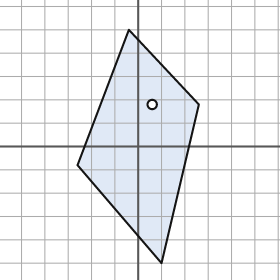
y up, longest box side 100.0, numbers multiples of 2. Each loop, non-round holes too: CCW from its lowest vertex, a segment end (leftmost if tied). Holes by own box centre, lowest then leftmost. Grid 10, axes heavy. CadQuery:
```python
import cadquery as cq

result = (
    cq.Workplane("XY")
    .moveTo(10.0, -50.0)
    .lineTo(26.0, 18.0)
    .lineTo(-4.0, 50.0)
    .lineTo(-26.0, -8.0)
    .close()
    .moveTo(6.0, 18.0)
    .circle(2.0)
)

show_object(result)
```